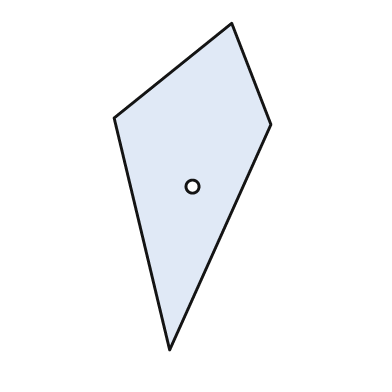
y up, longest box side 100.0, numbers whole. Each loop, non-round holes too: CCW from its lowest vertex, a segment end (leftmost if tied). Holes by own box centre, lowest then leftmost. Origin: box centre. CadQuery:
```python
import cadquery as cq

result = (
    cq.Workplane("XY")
    .moveTo(-7.0, -50.0)
    .lineTo(24.0, 19.0)
    .lineTo(12.0, 50.0)
    .lineTo(-24.0, 21.0)
    .close()
    .moveTo(0.0, 0.0)
    .circle(2.0)
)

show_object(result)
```